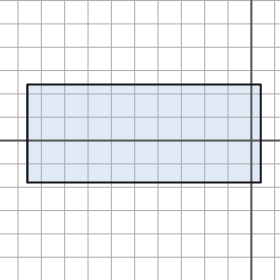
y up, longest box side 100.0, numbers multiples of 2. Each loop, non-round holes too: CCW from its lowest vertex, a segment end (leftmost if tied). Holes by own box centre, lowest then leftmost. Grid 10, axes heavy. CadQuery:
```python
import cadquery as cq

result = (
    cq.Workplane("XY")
    .moveTo(-96.0, -18.0)
    .lineTo(4.0, -18.0)
    .lineTo(4.0, 24.0)
    .lineTo(-96.0, 24.0)
    .close()
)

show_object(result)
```